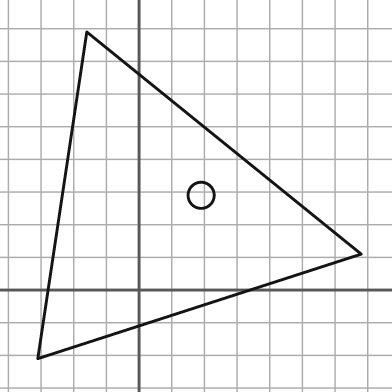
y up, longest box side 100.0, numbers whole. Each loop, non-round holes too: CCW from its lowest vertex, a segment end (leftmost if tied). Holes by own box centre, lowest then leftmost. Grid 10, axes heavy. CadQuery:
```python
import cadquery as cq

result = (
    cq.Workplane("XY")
    .moveTo(-31.0, -21.0)
    .lineTo(68.0, 11.0)
    .lineTo(-16.0, 79.0)
    .close()
    .moveTo(19.0, 29.0)
    .circle(4.0)
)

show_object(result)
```